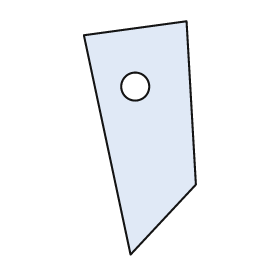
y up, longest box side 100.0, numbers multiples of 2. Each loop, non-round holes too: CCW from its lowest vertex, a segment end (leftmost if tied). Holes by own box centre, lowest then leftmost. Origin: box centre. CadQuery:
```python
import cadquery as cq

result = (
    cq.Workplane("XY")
    .moveTo(-4.0, -50.0)
    .lineTo(24.0, -20.0)
    .lineTo(20.0, 50.0)
    .lineTo(-24.0, 44.0)
    .close()
    .moveTo(-2.0, 22.0)
    .circle(6.0)
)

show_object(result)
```